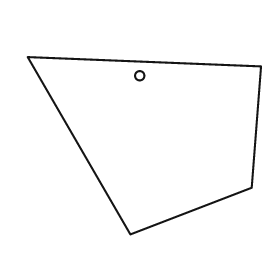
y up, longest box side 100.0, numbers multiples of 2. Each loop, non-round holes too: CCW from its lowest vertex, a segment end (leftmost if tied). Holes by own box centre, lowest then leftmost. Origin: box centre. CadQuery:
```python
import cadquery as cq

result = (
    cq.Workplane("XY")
    .moveTo(-6.0, -38.0)
    .lineTo(46.0, -18.0)
    .lineTo(50.0, 34.0)
    .lineTo(-50.0, 38.0)
    .close()
    .moveTo(-2.0, 30.0)
    .circle(2.0)
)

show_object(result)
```